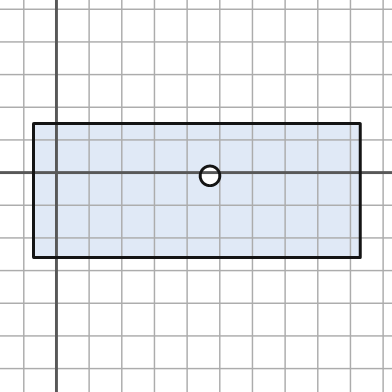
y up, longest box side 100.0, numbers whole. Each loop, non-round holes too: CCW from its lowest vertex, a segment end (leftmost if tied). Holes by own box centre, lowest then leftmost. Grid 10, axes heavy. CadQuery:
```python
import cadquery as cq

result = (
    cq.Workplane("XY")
    .moveTo(-7.0, -26.0)
    .lineTo(93.0, -26.0)
    .lineTo(93.0, 15.0)
    .lineTo(-7.0, 15.0)
    .close()
    .moveTo(47.0, -1.0)
    .circle(3.0)
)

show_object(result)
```